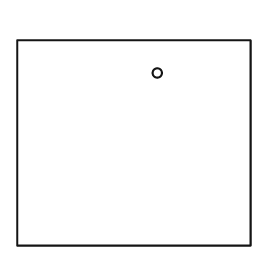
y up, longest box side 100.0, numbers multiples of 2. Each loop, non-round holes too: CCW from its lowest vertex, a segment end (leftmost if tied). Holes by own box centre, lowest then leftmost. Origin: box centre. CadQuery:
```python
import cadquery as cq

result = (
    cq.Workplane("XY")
    .moveTo(-50.0, -44.0)
    .lineTo(50.0, -44.0)
    .lineTo(50.0, 44.0)
    .lineTo(-50.0, 44.0)
    .close()
    .moveTo(10.0, 30.0)
    .circle(2.0)
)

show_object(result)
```